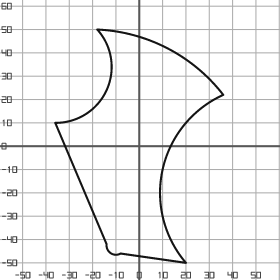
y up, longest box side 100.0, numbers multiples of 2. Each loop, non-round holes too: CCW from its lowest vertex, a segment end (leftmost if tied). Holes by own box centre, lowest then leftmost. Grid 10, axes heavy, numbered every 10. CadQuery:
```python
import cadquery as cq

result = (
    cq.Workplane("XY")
    .moveTo(20.0, -50.0)
    .threePointArc((10.0, -10.0), (36.0, 22.0))
    .threePointArc((12.0, 42.0), (-18.0, 50.0))
    .threePointArc((-14.0, 24.0), (-36.0, 10.0))
    .lineTo(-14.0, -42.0)
    .threePointArc((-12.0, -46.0), (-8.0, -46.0))
    .close()
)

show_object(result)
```